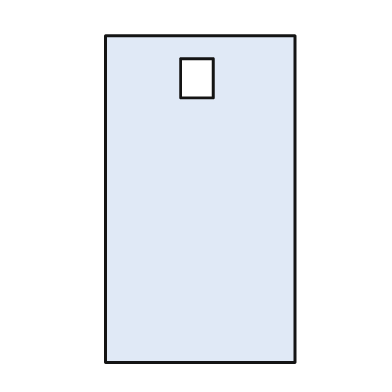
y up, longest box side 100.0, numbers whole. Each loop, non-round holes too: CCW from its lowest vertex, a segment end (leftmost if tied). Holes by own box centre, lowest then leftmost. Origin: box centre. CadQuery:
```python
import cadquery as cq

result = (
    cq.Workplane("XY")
    .moveTo(-29.0, -50.0)
    .lineTo(29.0, -50.0)
    .lineTo(29.0, 50.0)
    .lineTo(-29.0, 50.0)
    .close()
    .moveTo(-6.0, 31.0)
    .lineTo(4.0, 31.0)
    .lineTo(4.0, 43.0)
    .lineTo(-6.0, 43.0)
    .close()
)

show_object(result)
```